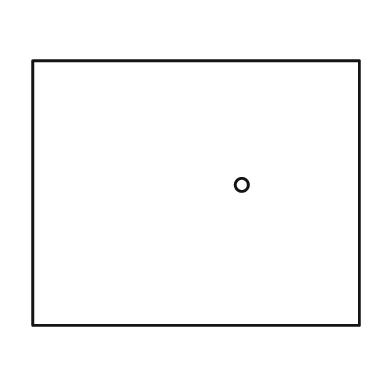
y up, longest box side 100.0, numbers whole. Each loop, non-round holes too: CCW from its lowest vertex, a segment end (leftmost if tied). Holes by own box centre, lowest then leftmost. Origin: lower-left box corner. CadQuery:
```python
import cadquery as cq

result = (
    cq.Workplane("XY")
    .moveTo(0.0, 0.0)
    .lineTo(100.0, 0.0)
    .lineTo(100.0, 81.0)
    .lineTo(0.0, 81.0)
    .close()
    .moveTo(64.0, 43.0)
    .circle(2.0)
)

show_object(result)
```